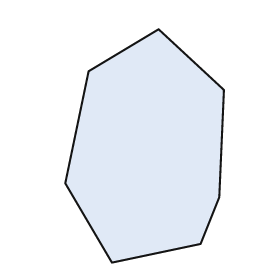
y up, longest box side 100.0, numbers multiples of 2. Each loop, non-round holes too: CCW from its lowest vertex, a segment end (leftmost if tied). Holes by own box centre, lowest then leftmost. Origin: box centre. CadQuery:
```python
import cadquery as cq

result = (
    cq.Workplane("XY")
    .moveTo(-14.0, -50.0)
    .lineTo(24.0, -42.0)
    .lineTo(32.0, -22.0)
    .lineTo(34.0, 24.0)
    .lineTo(6.0, 50.0)
    .lineTo(-24.0, 32.0)
    .lineTo(-34.0, -16.0)
    .close()
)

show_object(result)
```